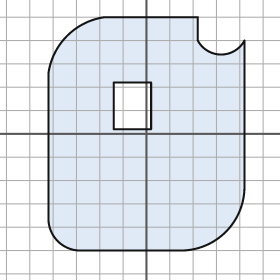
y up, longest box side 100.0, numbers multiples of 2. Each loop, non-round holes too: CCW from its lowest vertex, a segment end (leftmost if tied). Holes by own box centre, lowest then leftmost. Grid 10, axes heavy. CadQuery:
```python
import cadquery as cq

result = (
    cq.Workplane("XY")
    .moveTo(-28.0, -50.0)
    .lineTo(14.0, -50.0)
    .threePointArc((34.0, -42.0), (42.0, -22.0))
    .lineTo(42.0, 40.0)
    .threePointArc((32.0, 34.0), (22.0, 40.0))
    .lineTo(22.0, 50.0)
    .lineTo(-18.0, 50.0)
    .threePointArc((-34.0, 42.0), (-42.0, 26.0))
    .lineTo(-42.0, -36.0)
    .threePointArc((-38.0, -46.0), (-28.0, -50.0))
    .close()
    .moveTo(-14.0, 2.0)
    .lineTo(2.0, 2.0)
    .lineTo(2.0, 22.0)
    .lineTo(-14.0, 22.0)
    .close()
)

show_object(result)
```